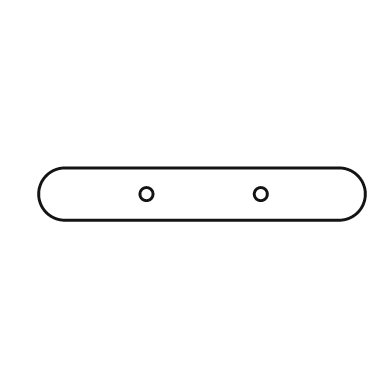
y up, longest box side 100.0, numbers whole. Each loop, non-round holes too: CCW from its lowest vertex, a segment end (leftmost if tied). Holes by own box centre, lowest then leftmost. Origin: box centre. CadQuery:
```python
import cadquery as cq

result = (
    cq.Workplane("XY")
    .moveTo(-42.0, -8.0)
    .lineTo(42.0, -8.0)
    .threePointArc((50.0, 0.0), (42.0, 8.0))
    .lineTo(-42.0, 8.0)
    .threePointArc((-50.0, 0.0), (-42.0, -8.0))
    .close()
    .moveTo(-17.0, 0.0)
    .circle(2.0)
    .moveTo(18.0, 0.0)
    .circle(2.0)
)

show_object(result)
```